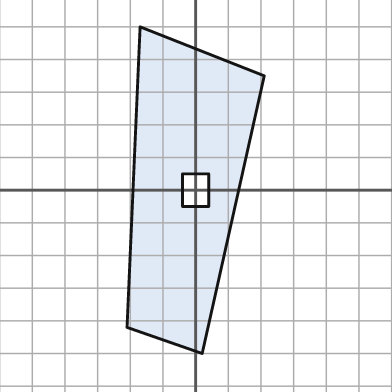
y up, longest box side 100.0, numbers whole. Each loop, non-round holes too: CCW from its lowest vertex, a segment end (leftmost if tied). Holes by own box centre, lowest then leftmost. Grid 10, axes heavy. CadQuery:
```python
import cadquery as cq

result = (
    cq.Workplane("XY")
    .moveTo(2.0, -50.0)
    .lineTo(21.0, 35.0)
    .lineTo(-17.0, 50.0)
    .lineTo(-21.0, -42.0)
    .close()
    .moveTo(-4.0, -5.0)
    .lineTo(4.0, -5.0)
    .lineTo(4.0, 5.0)
    .lineTo(-4.0, 5.0)
    .close()
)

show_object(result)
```